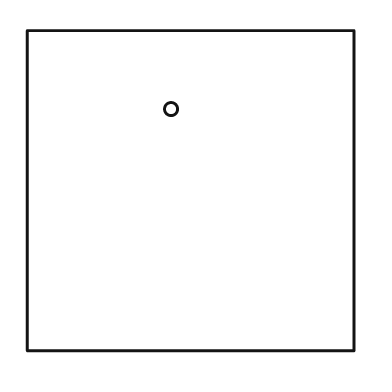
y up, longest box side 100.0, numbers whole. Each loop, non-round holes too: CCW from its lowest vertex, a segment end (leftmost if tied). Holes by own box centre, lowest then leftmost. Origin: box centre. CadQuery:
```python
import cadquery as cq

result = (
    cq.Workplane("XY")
    .moveTo(-50.0, -49.0)
    .lineTo(50.0, -49.0)
    .lineTo(50.0, 49.0)
    .lineTo(-50.0, 49.0)
    .close()
    .moveTo(-6.0, 25.0)
    .circle(2.0)
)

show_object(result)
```